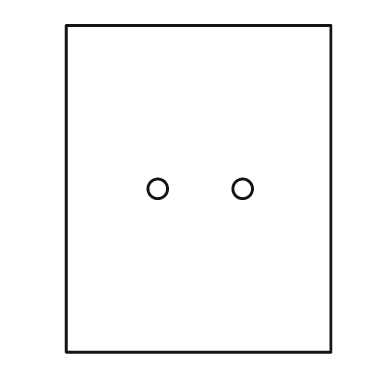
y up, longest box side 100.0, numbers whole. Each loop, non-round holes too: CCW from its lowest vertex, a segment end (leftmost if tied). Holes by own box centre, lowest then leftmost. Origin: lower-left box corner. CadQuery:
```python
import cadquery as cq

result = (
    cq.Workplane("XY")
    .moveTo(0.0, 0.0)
    .lineTo(81.0, 0.0)
    .lineTo(81.0, 100.0)
    .lineTo(0.0, 100.0)
    .close()
    .moveTo(28.0, 50.0)
    .circle(3.0)
    .moveTo(54.0, 50.0)
    .circle(3.0)
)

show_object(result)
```